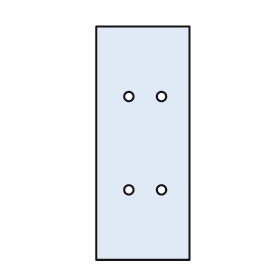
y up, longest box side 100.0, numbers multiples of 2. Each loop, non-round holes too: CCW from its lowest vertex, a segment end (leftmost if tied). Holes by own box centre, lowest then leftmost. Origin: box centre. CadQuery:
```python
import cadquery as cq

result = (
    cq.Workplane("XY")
    .moveTo(-20.0, -50.0)
    .lineTo(20.0, -50.0)
    .lineTo(20.0, 50.0)
    .lineTo(-20.0, 50.0)
    .close()
    .moveTo(-6.0, -20.0)
    .circle(2.0)
    .moveTo(8.0, -20.0)
    .circle(2.0)
    .moveTo(-6.0, 20.0)
    .circle(2.0)
    .moveTo(8.0, 20.0)
    .circle(2.0)
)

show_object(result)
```